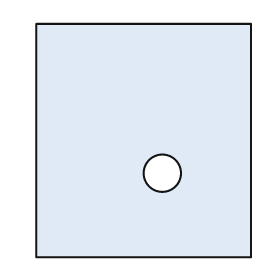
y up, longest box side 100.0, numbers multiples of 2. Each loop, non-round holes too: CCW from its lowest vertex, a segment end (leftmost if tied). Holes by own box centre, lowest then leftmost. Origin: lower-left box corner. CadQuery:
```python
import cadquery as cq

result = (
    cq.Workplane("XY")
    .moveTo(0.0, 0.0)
    .lineTo(92.0, 0.0)
    .lineTo(92.0, 100.0)
    .lineTo(0.0, 100.0)
    .close()
    .moveTo(54.0, 36.0)
    .circle(8.0)
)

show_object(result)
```